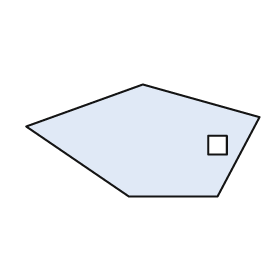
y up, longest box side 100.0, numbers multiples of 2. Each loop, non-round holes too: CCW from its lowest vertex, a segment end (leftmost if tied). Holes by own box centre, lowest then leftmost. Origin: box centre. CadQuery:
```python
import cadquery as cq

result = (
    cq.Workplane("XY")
    .moveTo(-6.0, -24.0)
    .lineTo(32.0, -24.0)
    .lineTo(50.0, 10.0)
    .lineTo(0.0, 24.0)
    .lineTo(-50.0, 6.0)
    .close()
    .moveTo(28.0, -6.0)
    .lineTo(36.0, -6.0)
    .lineTo(36.0, 2.0)
    .lineTo(28.0, 2.0)
    .close()
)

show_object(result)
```